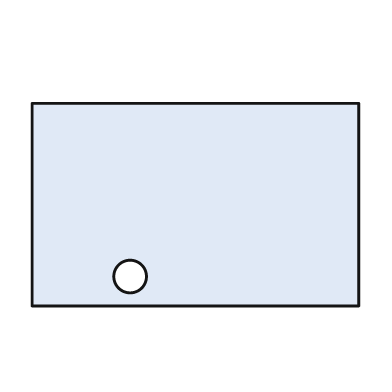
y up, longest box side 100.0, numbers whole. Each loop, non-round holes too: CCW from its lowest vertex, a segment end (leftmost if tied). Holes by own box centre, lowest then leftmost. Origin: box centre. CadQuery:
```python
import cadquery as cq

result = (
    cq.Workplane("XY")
    .moveTo(-50.0, -31.0)
    .lineTo(50.0, -31.0)
    .lineTo(50.0, 31.0)
    .lineTo(-50.0, 31.0)
    .close()
    .moveTo(-20.0, -22.0)
    .circle(5.0)
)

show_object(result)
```